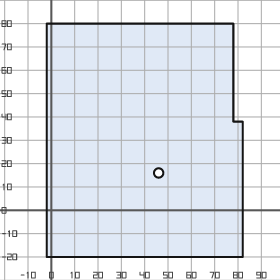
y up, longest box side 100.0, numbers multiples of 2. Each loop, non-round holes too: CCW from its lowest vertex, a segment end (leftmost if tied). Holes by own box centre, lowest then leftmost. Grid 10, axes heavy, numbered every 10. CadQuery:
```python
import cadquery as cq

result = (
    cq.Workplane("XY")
    .moveTo(-2.0, -20.0)
    .lineTo(82.0, -20.0)
    .lineTo(82.0, 38.0)
    .lineTo(78.0, 38.0)
    .lineTo(78.0, 80.0)
    .lineTo(-2.0, 80.0)
    .close()
    .moveTo(46.0, 16.0)
    .circle(2.0)
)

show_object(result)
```